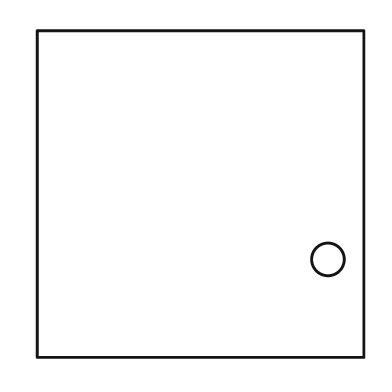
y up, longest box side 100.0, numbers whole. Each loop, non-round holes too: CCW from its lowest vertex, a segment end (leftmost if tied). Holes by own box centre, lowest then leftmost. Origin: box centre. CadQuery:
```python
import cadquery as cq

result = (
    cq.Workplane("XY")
    .moveTo(-50.0, -50.0)
    .lineTo(50.0, -50.0)
    .lineTo(50.0, 50.0)
    .lineTo(-50.0, 50.0)
    .close()
    .moveTo(39.0, -20.0)
    .circle(5.0)
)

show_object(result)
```